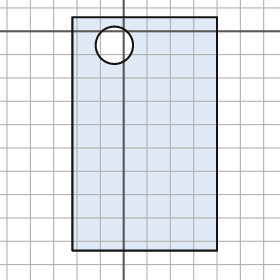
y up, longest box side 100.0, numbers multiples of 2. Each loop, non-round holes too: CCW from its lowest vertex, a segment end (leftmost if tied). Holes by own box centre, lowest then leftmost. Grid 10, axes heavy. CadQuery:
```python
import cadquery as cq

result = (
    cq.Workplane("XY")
    .moveTo(-22.0, -94.0)
    .lineTo(40.0, -94.0)
    .lineTo(40.0, 6.0)
    .lineTo(-22.0, 6.0)
    .close()
    .moveTo(-4.0, -6.0)
    .circle(8.0)
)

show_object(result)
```